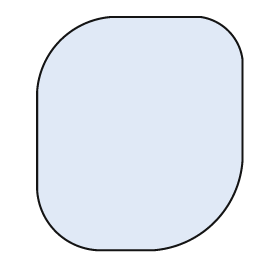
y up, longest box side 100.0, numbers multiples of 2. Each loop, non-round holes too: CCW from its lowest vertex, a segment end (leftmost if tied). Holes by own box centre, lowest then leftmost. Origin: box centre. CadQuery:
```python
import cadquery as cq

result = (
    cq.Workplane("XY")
    .moveTo(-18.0, -50.0)
    .lineTo(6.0, -50.0)
    .threePointArc((32.0, -38.0), (44.0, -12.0))
    .lineTo(44.0, 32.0)
    .threePointArc((38.0, 44.0), (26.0, 50.0))
    .lineTo(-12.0, 50.0)
    .threePointArc((-34.0, 40.0), (-44.0, 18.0))
    .lineTo(-44.0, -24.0)
    .threePointArc((-36.0, -42.0), (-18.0, -50.0))
    .close()
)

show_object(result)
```